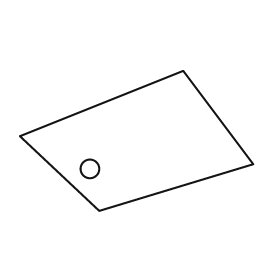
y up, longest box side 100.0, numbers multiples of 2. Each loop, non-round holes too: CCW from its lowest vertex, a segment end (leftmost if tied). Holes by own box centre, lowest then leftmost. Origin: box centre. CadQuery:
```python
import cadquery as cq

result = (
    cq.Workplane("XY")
    .moveTo(-16.0, -30.0)
    .lineTo(50.0, -10.0)
    .lineTo(20.0, 30.0)
    .lineTo(-50.0, 2.0)
    .close()
    .moveTo(-20.0, -12.0)
    .circle(4.0)
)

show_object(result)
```